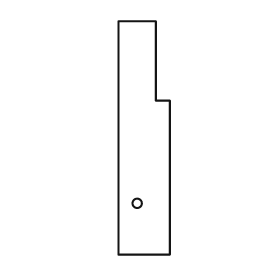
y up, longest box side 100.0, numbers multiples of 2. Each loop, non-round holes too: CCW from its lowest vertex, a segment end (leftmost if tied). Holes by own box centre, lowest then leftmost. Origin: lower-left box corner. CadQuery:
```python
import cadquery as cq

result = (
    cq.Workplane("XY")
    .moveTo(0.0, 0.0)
    .lineTo(22.0, 0.0)
    .lineTo(22.0, 66.0)
    .lineTo(16.0, 66.0)
    .lineTo(16.0, 100.0)
    .lineTo(0.0, 100.0)
    .close()
    .moveTo(8.0, 22.0)
    .circle(2.0)
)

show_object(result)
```